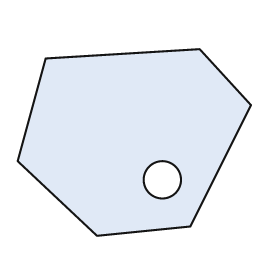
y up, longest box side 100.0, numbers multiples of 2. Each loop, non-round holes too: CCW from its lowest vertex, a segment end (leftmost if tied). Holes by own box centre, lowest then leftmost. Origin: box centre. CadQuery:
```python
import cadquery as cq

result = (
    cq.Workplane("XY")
    .moveTo(-16.0, -40.0)
    .lineTo(24.0, -36.0)
    .lineTo(50.0, 16.0)
    .lineTo(28.0, 40.0)
    .lineTo(-38.0, 36.0)
    .lineTo(-50.0, -8.0)
    .close()
    .moveTo(12.0, -16.0)
    .circle(8.0)
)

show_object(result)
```